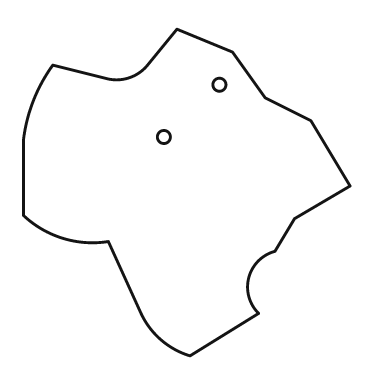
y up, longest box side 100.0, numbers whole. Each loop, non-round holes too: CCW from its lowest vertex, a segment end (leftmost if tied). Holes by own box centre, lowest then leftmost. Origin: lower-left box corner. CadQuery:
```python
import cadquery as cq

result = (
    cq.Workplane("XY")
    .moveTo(51.0, 0.0)
    .lineTo(72.0, 13.0)
    .threePointArc((69.0, 24.0), (77.0, 32.0))
    .lineTo(83.0, 42.0)
    .lineTo(100.0, 52.0)
    .lineTo(88.0, 72.0)
    .lineTo(74.0, 79.0)
    .lineTo(64.0, 93.0)
    .lineTo(47.0, 100.0)
    .lineTo(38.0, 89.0)
    .threePointArc((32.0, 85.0), (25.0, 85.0))
    .lineTo(9.0, 89.0)
    .threePointArc((3.0, 78.0), (0.0, 66.0))
    .lineTo(0.0, 43.0)
    .threePointArc((12.0, 36.0), (26.0, 35.0))
    .lineTo(36.0, 13.0)
    .threePointArc((42.0, 5.0), (51.0, 0.0))
    .close()
    .moveTo(43.0, 67.0)
    .circle(2.0)
    .moveTo(60.0, 83.0)
    .circle(2.0)
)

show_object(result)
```